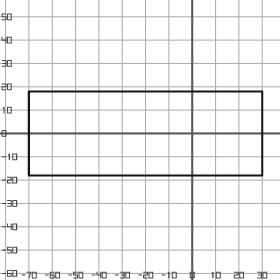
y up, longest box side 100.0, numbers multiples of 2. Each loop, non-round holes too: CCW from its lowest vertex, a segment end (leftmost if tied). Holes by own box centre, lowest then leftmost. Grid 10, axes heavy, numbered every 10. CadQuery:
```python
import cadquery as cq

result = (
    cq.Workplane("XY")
    .moveTo(-70.0, -18.0)
    .lineTo(30.0, -18.0)
    .lineTo(30.0, 18.0)
    .lineTo(-70.0, 18.0)
    .close()
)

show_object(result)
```